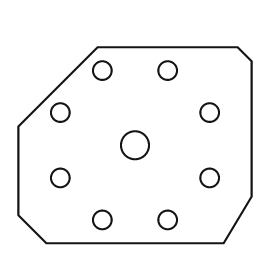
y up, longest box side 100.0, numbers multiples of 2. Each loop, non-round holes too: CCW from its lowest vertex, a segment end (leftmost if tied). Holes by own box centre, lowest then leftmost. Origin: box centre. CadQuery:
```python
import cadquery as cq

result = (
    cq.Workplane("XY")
    .moveTo(-38.0, -42.0)
    .lineTo(38.0, -42.0)
    .lineTo(50.0, -22.0)
    .lineTo(50.0, 36.0)
    .lineTo(44.0, 42.0)
    .lineTo(-16.0, 42.0)
    .lineTo(-50.0, 8.0)
    .lineTo(-50.0, -30.0)
    .close()
    .moveTo(-14.0, -32.0)
    .circle(4.0)
    .moveTo(14.0, -32.0)
    .circle(4.0)
    .moveTo(-32.0, -14.0)
    .circle(4.0)
    .moveTo(32.0, -14.0)
    .circle(4.0)
    .moveTo(0.0, 0.0)
    .circle(6.0)
    .moveTo(-32.0, 14.0)
    .circle(4.0)
    .moveTo(32.0, 14.0)
    .circle(4.0)
    .moveTo(-14.0, 32.0)
    .circle(4.0)
    .moveTo(14.0, 32.0)
    .circle(4.0)
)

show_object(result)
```